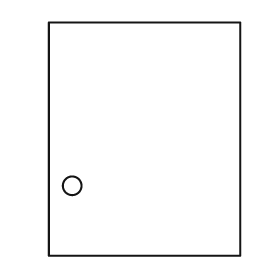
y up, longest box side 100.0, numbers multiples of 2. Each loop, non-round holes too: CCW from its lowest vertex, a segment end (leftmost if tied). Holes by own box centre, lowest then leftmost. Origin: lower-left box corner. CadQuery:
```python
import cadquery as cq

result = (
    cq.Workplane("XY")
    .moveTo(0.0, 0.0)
    .lineTo(82.0, 0.0)
    .lineTo(82.0, 100.0)
    .lineTo(0.0, 100.0)
    .close()
    .moveTo(10.0, 30.0)
    .circle(4.0)
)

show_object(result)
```